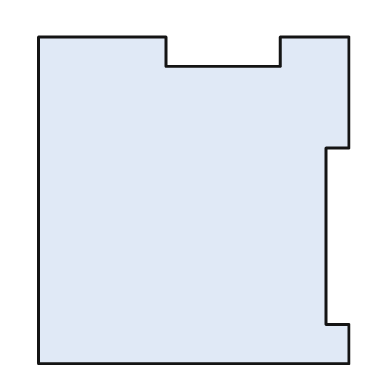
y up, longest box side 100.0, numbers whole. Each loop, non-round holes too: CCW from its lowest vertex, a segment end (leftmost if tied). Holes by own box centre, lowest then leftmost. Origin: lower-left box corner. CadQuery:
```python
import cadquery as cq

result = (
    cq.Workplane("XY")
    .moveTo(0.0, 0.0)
    .lineTo(95.0, 0.0)
    .lineTo(95.0, 12.0)
    .lineTo(88.0, 12.0)
    .lineTo(88.0, 66.0)
    .lineTo(95.0, 66.0)
    .lineTo(95.0, 100.0)
    .lineTo(74.0, 100.0)
    .lineTo(74.0, 91.0)
    .lineTo(39.0, 91.0)
    .lineTo(39.0, 100.0)
    .lineTo(0.0, 100.0)
    .close()
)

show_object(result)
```